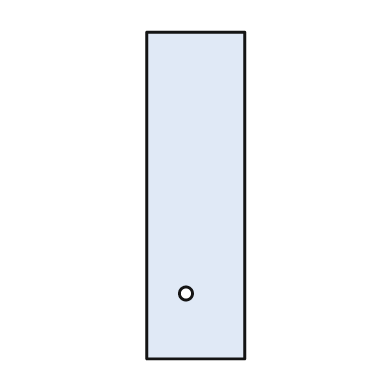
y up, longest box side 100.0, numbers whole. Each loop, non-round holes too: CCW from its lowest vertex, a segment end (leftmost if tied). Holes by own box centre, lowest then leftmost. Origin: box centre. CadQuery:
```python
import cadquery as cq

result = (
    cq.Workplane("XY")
    .moveTo(-15.0, -50.0)
    .lineTo(15.0, -50.0)
    .lineTo(15.0, 50.0)
    .lineTo(-15.0, 50.0)
    .close()
    .moveTo(-3.0, -30.0)
    .circle(2.0)
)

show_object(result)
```